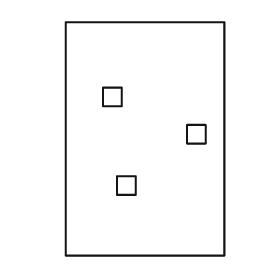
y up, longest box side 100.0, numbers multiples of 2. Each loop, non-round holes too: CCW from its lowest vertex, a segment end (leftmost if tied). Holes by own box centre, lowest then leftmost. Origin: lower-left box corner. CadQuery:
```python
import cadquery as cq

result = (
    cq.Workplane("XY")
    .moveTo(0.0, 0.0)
    .lineTo(68.0, 0.0)
    .lineTo(68.0, 100.0)
    .lineTo(0.0, 100.0)
    .close()
    .moveTo(22.0, 26.0)
    .lineTo(30.0, 26.0)
    .lineTo(30.0, 34.0)
    .lineTo(22.0, 34.0)
    .close()
    .moveTo(52.0, 48.0)
    .lineTo(60.0, 48.0)
    .lineTo(60.0, 56.0)
    .lineTo(52.0, 56.0)
    .close()
    .moveTo(16.0, 64.0)
    .lineTo(24.0, 64.0)
    .lineTo(24.0, 72.0)
    .lineTo(16.0, 72.0)
    .close()
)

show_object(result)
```